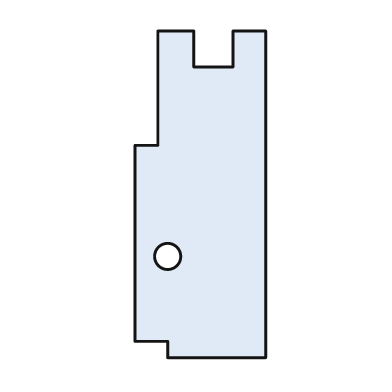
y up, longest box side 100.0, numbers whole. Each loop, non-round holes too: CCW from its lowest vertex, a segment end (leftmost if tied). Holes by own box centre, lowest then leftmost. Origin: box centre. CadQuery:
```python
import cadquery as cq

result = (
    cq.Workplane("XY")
    .moveTo(-10.0, -50.0)
    .lineTo(20.0, -50.0)
    .lineTo(20.0, 50.0)
    .lineTo(10.0, 50.0)
    .lineTo(10.0, 39.0)
    .lineTo(-2.0, 39.0)
    .lineTo(-2.0, 50.0)
    .lineTo(-13.0, 50.0)
    .lineTo(-13.0, 15.0)
    .lineTo(-20.0, 15.0)
    .lineTo(-20.0, -45.0)
    .lineTo(-10.0, -45.0)
    .close()
    .moveTo(-10.0, -19.0)
    .circle(4.0)
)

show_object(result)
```